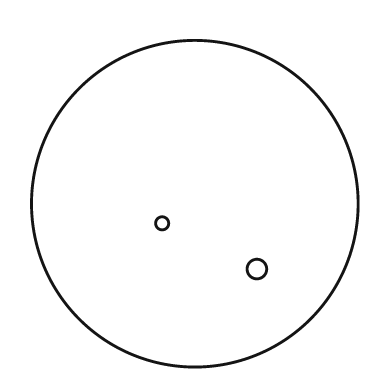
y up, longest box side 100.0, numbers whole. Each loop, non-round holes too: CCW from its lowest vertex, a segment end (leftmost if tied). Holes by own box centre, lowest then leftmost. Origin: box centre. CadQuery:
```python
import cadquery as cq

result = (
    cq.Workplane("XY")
    .moveTo(0.0, 0.0)
    .circle(50.0)
    .moveTo(19.0, -20.0)
    .circle(3.0)
    .moveTo(-10.0, -6.0)
    .circle(2.0)
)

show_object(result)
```